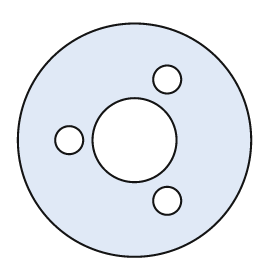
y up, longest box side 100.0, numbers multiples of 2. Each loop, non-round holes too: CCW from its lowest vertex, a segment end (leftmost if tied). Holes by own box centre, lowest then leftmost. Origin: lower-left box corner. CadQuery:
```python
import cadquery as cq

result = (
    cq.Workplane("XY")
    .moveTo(50.0, 50.0)
    .circle(50.0)
    .moveTo(64.0, 24.0)
    .circle(6.0)
    .moveTo(22.0, 50.0)
    .circle(6.0)
    .moveTo(50.0, 50.0)
    .circle(18.0)
    .moveTo(64.0, 76.0)
    .circle(6.0)
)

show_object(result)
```